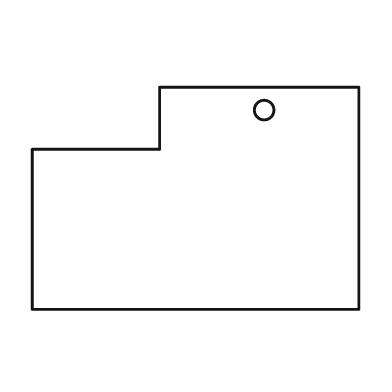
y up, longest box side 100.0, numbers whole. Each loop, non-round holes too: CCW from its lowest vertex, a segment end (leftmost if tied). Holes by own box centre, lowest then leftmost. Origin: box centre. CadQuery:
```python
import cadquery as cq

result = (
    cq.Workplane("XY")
    .moveTo(-50.0, -34.0)
    .lineTo(50.0, -34.0)
    .lineTo(50.0, 34.0)
    .lineTo(-11.0, 34.0)
    .lineTo(-11.0, 15.0)
    .lineTo(-50.0, 15.0)
    .close()
    .moveTo(21.0, 27.0)
    .circle(3.0)
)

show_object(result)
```